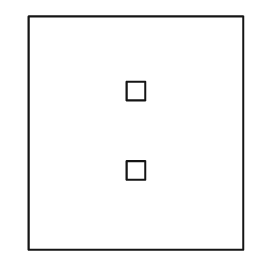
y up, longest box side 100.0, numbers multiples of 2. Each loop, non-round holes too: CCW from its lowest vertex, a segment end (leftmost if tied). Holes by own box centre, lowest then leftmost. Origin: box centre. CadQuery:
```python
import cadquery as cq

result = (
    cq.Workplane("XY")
    .moveTo(-46.0, -50.0)
    .lineTo(46.0, -50.0)
    .lineTo(46.0, 50.0)
    .lineTo(-46.0, 50.0)
    .close()
    .moveTo(-4.0, -20.0)
    .lineTo(4.0, -20.0)
    .lineTo(4.0, -12.0)
    .lineTo(-4.0, -12.0)
    .close()
    .moveTo(-4.0, 14.0)
    .lineTo(4.0, 14.0)
    .lineTo(4.0, 22.0)
    .lineTo(-4.0, 22.0)
    .close()
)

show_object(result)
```